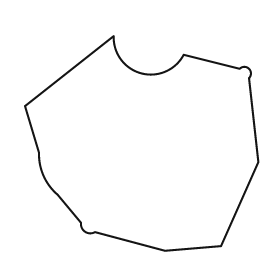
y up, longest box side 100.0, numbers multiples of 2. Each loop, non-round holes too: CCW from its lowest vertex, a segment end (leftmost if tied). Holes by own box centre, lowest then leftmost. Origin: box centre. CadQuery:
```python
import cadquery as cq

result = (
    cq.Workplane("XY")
    .moveTo(10.0, -46.0)
    .lineTo(34.0, -44.0)
    .lineTo(50.0, -8.0)
    .lineTo(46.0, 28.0)
    .threePointArc((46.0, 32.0), (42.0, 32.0))
    .lineTo(18.0, 38.0)
    .threePointArc((0.0, 30.0), (-12.0, 46.0))
    .lineTo(-50.0, 16.0)
    .lineTo(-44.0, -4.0)
    .threePointArc((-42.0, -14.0), (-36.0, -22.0))
    .lineTo(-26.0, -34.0)
    .threePointArc((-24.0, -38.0), (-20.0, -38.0))
    .close()
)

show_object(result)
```